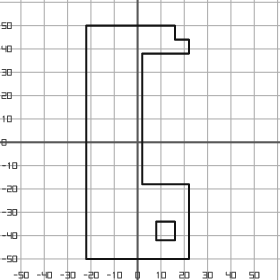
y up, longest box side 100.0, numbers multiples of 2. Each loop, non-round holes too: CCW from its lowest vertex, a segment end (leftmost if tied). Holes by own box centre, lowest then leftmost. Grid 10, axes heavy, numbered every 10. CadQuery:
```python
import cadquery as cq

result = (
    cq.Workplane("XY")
    .moveTo(-22.0, -50.0)
    .lineTo(22.0, -50.0)
    .lineTo(22.0, -18.0)
    .lineTo(2.0, -18.0)
    .lineTo(2.0, 38.0)
    .lineTo(22.0, 38.0)
    .lineTo(22.0, 44.0)
    .lineTo(16.0, 44.0)
    .lineTo(16.0, 50.0)
    .lineTo(-22.0, 50.0)
    .close()
    .moveTo(8.0, -42.0)
    .lineTo(16.0, -42.0)
    .lineTo(16.0, -34.0)
    .lineTo(8.0, -34.0)
    .close()
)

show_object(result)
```